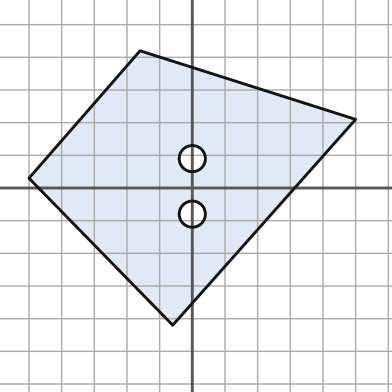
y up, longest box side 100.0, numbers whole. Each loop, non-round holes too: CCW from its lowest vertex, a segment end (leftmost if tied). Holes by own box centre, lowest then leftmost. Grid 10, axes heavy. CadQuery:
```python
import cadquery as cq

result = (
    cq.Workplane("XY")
    .moveTo(-6.0, -42.0)
    .lineTo(50.0, 21.0)
    .lineTo(-16.0, 42.0)
    .lineTo(-50.0, 3.0)
    .close()
    .moveTo(0.0, -8.0)
    .circle(4.0)
    .moveTo(0.0, 9.0)
    .circle(4.0)
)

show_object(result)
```